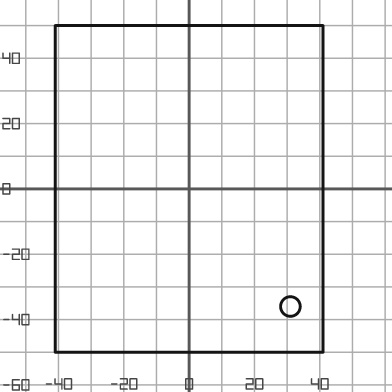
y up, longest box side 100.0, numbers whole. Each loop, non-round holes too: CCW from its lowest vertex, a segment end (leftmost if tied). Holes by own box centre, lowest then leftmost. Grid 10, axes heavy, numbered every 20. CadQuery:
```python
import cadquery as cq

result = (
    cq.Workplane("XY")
    .moveTo(-41.0, -50.0)
    .lineTo(41.0, -50.0)
    .lineTo(41.0, 50.0)
    .lineTo(-41.0, 50.0)
    .close()
    .moveTo(31.0, -36.0)
    .circle(3.0)
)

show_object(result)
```